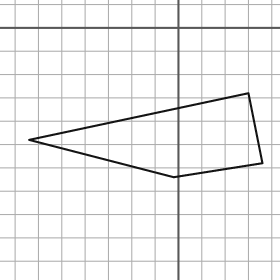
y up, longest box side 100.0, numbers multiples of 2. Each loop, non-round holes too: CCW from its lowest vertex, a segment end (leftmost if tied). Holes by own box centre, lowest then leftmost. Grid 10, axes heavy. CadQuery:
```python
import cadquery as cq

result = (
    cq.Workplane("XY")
    .moveTo(-2.0, -64.0)
    .lineTo(36.0, -58.0)
    .lineTo(30.0, -28.0)
    .lineTo(-64.0, -48.0)
    .close()
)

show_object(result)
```